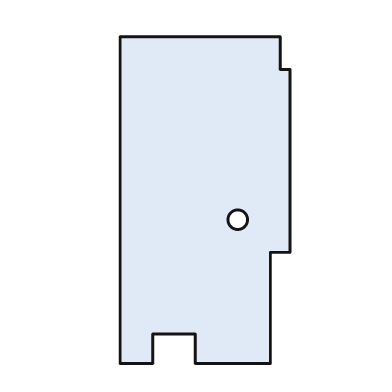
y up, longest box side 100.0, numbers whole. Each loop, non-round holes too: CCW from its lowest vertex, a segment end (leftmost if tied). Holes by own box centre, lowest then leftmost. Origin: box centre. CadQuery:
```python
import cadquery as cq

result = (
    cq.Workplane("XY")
    .moveTo(-26.0, -50.0)
    .lineTo(-16.0, -50.0)
    .lineTo(-16.0, -41.0)
    .lineTo(-3.0, -41.0)
    .lineTo(-3.0, -50.0)
    .lineTo(20.0, -50.0)
    .lineTo(20.0, -16.0)
    .lineTo(26.0, -16.0)
    .lineTo(26.0, 40.0)
    .lineTo(23.0, 40.0)
    .lineTo(23.0, 50.0)
    .lineTo(-26.0, 50.0)
    .close()
    .moveTo(10.0, -6.0)
    .circle(3.0)
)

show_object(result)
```